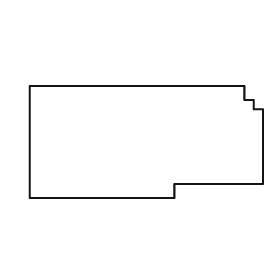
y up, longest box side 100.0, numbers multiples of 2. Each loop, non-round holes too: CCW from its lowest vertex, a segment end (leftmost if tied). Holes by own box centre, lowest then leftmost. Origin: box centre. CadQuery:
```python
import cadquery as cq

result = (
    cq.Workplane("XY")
    .moveTo(-50.0, -24.0)
    .lineTo(12.0, -24.0)
    .lineTo(12.0, -18.0)
    .lineTo(50.0, -18.0)
    .lineTo(50.0, 14.0)
    .lineTo(46.0, 14.0)
    .lineTo(46.0, 18.0)
    .lineTo(42.0, 18.0)
    .lineTo(42.0, 24.0)
    .lineTo(-50.0, 24.0)
    .close()
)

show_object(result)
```